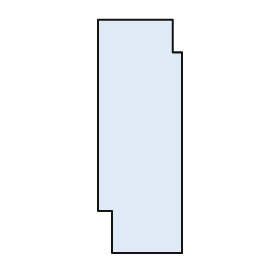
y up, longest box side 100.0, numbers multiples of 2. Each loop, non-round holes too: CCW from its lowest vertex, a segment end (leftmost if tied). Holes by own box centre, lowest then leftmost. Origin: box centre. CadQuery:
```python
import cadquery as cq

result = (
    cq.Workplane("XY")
    .moveTo(-12.0, -50.0)
    .lineTo(18.0, -50.0)
    .lineTo(18.0, 36.0)
    .lineTo(14.0, 36.0)
    .lineTo(14.0, 50.0)
    .lineTo(-18.0, 50.0)
    .lineTo(-18.0, -32.0)
    .lineTo(-12.0, -32.0)
    .close()
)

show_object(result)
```